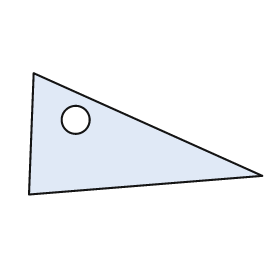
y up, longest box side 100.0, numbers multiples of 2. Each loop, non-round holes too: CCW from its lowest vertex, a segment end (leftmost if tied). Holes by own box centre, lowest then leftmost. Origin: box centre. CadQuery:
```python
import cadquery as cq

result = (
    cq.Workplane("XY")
    .moveTo(-50.0, -26.0)
    .lineTo(50.0, -18.0)
    .lineTo(-48.0, 26.0)
    .close()
    .moveTo(-30.0, 6.0)
    .circle(6.0)
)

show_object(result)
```